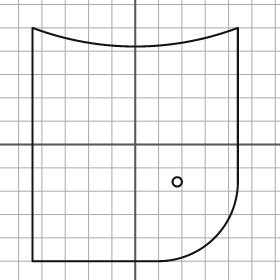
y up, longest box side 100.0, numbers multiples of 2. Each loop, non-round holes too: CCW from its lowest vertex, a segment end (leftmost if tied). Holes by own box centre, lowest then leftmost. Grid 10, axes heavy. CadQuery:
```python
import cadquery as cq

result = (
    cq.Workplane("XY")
    .moveTo(-44.0, -50.0)
    .lineTo(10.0, -50.0)
    .threePointArc((34.0, -40.0), (44.0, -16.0))
    .lineTo(44.0, 50.0)
    .threePointArc((0.0, 42.0), (-44.0, 50.0))
    .close()
    .moveTo(18.0, -16.0)
    .circle(2.0)
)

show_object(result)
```